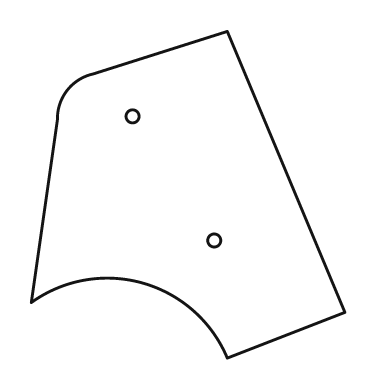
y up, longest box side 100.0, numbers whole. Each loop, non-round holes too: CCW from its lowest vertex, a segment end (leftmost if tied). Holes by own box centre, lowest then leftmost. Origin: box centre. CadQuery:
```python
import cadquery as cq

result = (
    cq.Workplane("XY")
    .moveTo(12.0, -50.0)
    .lineTo(48.0, -36.0)
    .lineTo(12.0, 50.0)
    .lineTo(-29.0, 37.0)
    .threePointArc((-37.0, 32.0), (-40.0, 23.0))
    .lineTo(-48.0, -33.0)
    .threePointArc((-14.0, -27.0), (12.0, -50.0))
    .close()
    .moveTo(8.0, -14.0)
    .circle(2.0)
    .moveTo(-17.0, 24.0)
    .circle(2.0)
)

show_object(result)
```